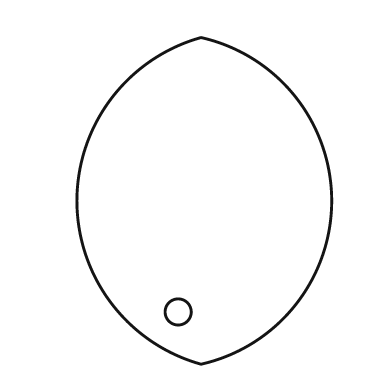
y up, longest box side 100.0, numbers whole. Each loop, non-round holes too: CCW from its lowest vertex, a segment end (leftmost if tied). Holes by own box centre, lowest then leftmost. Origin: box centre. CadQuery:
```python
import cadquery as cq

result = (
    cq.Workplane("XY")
    .moveTo(-1.0, -50.0)
    .threePointArc((39.0, 0.0), (-1.0, 50.0))
    .threePointArc((-39.0, 0.0), (-1.0, -50.0))
    .close()
    .moveTo(-8.0, -34.0)
    .circle(4.0)
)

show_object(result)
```